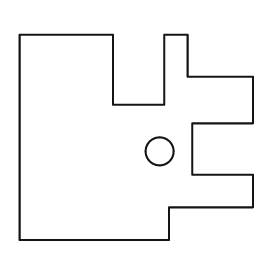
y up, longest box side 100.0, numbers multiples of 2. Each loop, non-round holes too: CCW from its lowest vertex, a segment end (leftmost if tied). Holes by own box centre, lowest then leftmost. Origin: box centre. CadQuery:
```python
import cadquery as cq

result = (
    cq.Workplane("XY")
    .moveTo(-50.0, -44.0)
    .lineTo(14.0, -44.0)
    .lineTo(14.0, -30.0)
    .lineTo(50.0, -30.0)
    .lineTo(50.0, -16.0)
    .lineTo(24.0, -16.0)
    .lineTo(24.0, 6.0)
    .lineTo(50.0, 6.0)
    .lineTo(50.0, 26.0)
    .lineTo(22.0, 26.0)
    .lineTo(22.0, 44.0)
    .lineTo(12.0, 44.0)
    .lineTo(12.0, 14.0)
    .lineTo(-10.0, 14.0)
    .lineTo(-10.0, 44.0)
    .lineTo(-50.0, 44.0)
    .close()
    .moveTo(10.0, -6.0)
    .circle(6.0)
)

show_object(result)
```